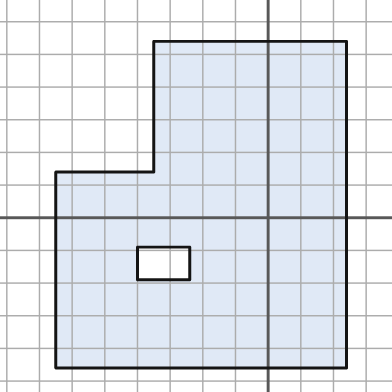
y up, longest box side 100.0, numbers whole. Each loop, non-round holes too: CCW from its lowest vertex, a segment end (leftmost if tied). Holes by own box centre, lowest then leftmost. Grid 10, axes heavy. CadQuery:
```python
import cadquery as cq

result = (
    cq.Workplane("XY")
    .moveTo(-65.0, -46.0)
    .lineTo(24.0, -46.0)
    .lineTo(24.0, 54.0)
    .lineTo(-35.0, 54.0)
    .lineTo(-35.0, 14.0)
    .lineTo(-65.0, 14.0)
    .close()
    .moveTo(-40.0, -19.0)
    .lineTo(-24.0, -19.0)
    .lineTo(-24.0, -9.0)
    .lineTo(-40.0, -9.0)
    .close()
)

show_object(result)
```